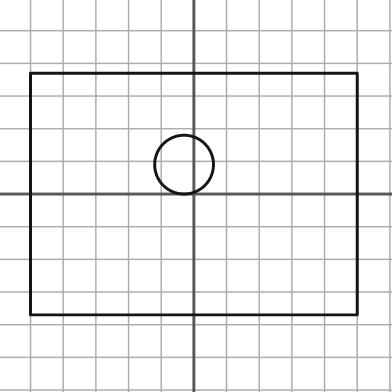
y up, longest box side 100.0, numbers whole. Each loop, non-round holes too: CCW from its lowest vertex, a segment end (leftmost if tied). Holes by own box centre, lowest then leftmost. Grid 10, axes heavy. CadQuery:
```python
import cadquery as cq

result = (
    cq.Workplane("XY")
    .moveTo(-50.0, -37.0)
    .lineTo(50.0, -37.0)
    .lineTo(50.0, 37.0)
    .lineTo(-50.0, 37.0)
    .close()
    .moveTo(-3.0, 9.0)
    .circle(9.0)
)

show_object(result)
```